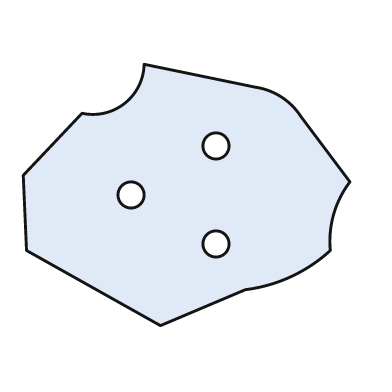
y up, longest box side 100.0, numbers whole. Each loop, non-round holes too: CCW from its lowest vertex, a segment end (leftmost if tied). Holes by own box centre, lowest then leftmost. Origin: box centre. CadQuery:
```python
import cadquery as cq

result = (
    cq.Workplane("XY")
    .moveTo(-8.0, -40.0)
    .lineTo(18.0, -29.0)
    .threePointArc((32.0, -25.0), (44.0, -17.0))
    .threePointArc((45.0, -6.0), (50.0, 4.0))
    .lineTo(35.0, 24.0)
    .threePointArc((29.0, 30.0), (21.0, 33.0))
    .lineTo(-13.0, 40.0)
    .threePointArc((-19.0, 28.0), (-32.0, 25.0))
    .lineTo(-50.0, 6.0)
    .lineTo(-49.0, -17.0)
    .close()
    .moveTo(9.0, -15.0)
    .circle(4.0)
    .moveTo(-17.0, 0.0)
    .circle(4.0)
    .moveTo(9.0, 15.0)
    .circle(4.0)
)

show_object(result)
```